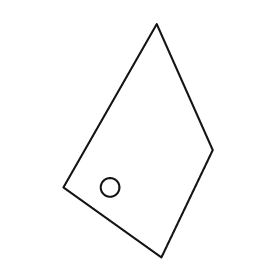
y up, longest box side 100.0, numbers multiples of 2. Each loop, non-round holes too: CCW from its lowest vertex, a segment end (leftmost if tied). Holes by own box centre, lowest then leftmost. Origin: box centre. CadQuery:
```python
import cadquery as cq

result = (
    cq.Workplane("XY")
    .moveTo(10.0, -50.0)
    .lineTo(32.0, -4.0)
    .lineTo(8.0, 50.0)
    .lineTo(-32.0, -20.0)
    .close()
    .moveTo(-12.0, -20.0)
    .circle(4.0)
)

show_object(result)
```